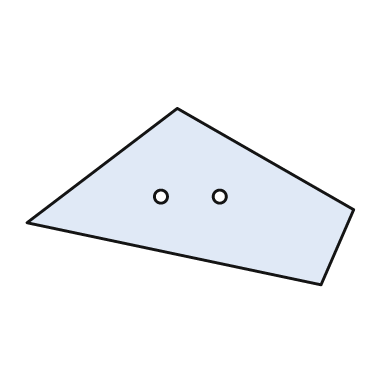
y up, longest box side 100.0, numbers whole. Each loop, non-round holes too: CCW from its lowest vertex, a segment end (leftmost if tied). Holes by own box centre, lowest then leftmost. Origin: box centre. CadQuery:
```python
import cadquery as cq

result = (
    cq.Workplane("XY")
    .moveTo(40.0, -27.0)
    .lineTo(50.0, -4.0)
    .lineTo(-4.0, 27.0)
    .lineTo(-50.0, -8.0)
    .close()
    .moveTo(-9.0, 0.0)
    .circle(2.0)
    .moveTo(9.0, 0.0)
    .circle(2.0)
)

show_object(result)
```